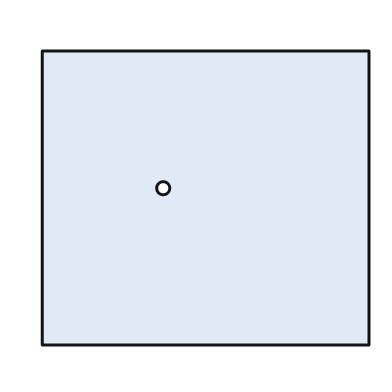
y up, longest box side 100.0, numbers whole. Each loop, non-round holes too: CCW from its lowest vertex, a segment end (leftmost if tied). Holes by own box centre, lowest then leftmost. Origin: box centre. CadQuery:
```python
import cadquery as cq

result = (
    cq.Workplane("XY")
    .moveTo(-50.0, -45.0)
    .lineTo(50.0, -45.0)
    .lineTo(50.0, 45.0)
    .lineTo(-50.0, 45.0)
    .close()
    .moveTo(-13.0, 3.0)
    .circle(2.0)
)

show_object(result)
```